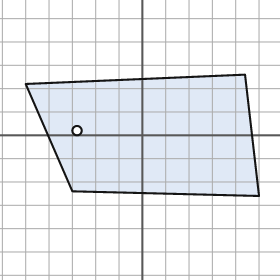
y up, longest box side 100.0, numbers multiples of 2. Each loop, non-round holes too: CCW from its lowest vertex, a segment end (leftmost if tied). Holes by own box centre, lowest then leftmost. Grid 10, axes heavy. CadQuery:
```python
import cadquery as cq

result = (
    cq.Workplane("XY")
    .moveTo(50.0, -26.0)
    .lineTo(44.0, 26.0)
    .lineTo(-50.0, 22.0)
    .lineTo(-30.0, -24.0)
    .close()
    .moveTo(-28.0, 2.0)
    .circle(2.0)
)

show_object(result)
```